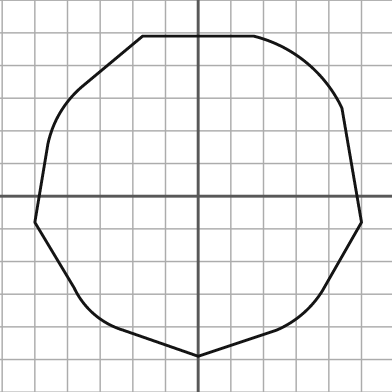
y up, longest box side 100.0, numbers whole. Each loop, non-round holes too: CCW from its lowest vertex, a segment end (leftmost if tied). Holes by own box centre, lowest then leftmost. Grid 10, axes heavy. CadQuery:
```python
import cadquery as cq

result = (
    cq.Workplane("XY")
    .moveTo(0.0, -49.0)
    .lineTo(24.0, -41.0)
    .threePointArc((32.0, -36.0), (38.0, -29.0))
    .lineTo(50.0, -8.0)
    .lineTo(44.0, 27.0)
    .threePointArc((33.0, 41.0), (17.0, 49.0))
    .lineTo(-17.0, 49.0)
    .lineTo(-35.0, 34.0)
    .threePointArc((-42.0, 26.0), (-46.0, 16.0))
    .lineTo(-50.0, -8.0)
    .lineTo(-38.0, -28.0)
    .threePointArc((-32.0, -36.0), (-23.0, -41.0))
    .close()
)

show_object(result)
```